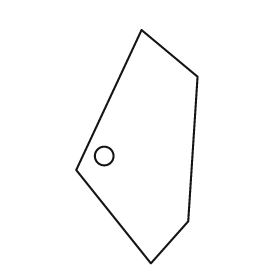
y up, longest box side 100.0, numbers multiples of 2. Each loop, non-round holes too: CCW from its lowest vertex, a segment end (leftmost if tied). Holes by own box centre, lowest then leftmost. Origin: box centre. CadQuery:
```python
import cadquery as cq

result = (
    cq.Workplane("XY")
    .moveTo(6.0, -50.0)
    .lineTo(22.0, -32.0)
    .lineTo(26.0, 30.0)
    .lineTo(2.0, 50.0)
    .lineTo(-26.0, -10.0)
    .close()
    .moveTo(-14.0, -4.0)
    .circle(4.0)
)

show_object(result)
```